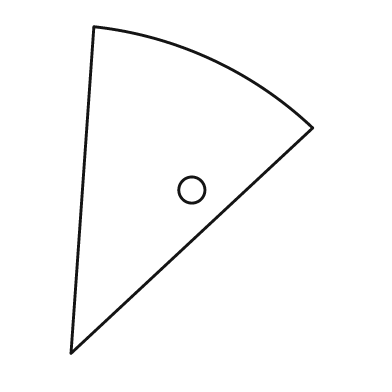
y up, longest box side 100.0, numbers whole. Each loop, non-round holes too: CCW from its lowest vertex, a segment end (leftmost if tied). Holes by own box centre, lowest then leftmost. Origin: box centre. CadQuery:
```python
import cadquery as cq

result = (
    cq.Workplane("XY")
    .moveTo(-37.0, -50.0)
    .lineTo(37.0, 19.0)
    .threePointArc((6.0, 40.0), (-30.0, 50.0))
    .close()
    .moveTo(0.0, 0.0)
    .circle(4.0)
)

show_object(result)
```